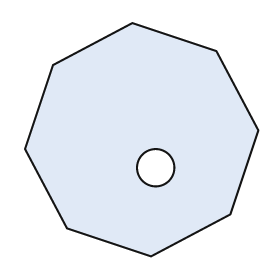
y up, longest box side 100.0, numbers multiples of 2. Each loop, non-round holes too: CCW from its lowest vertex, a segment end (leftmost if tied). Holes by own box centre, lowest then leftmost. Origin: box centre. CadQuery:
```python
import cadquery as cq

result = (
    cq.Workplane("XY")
    .moveTo(4.0, -50.0)
    .lineTo(38.0, -32.0)
    .lineTo(50.0, 4.0)
    .lineTo(32.0, 38.0)
    .lineTo(-4.0, 50.0)
    .lineTo(-38.0, 32.0)
    .lineTo(-50.0, -4.0)
    .lineTo(-32.0, -38.0)
    .close()
    .moveTo(6.0, -12.0)
    .circle(8.0)
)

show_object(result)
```